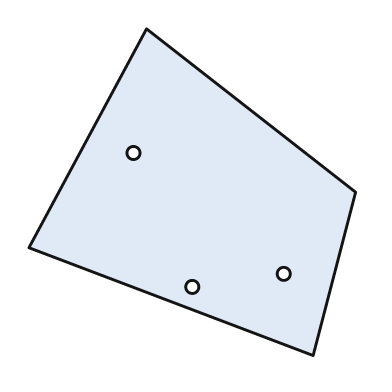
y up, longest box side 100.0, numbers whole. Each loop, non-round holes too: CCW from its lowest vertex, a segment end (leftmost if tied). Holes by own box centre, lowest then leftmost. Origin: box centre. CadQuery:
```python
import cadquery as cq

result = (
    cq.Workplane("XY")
    .moveTo(37.0, -50.0)
    .lineTo(50.0, 0.0)
    .lineTo(-14.0, 50.0)
    .lineTo(-50.0, -17.0)
    .close()
    .moveTo(0.0, -29.0)
    .circle(2.0)
    .moveTo(28.0, -25.0)
    .circle(2.0)
    .moveTo(-18.0, 12.0)
    .circle(2.0)
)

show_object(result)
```